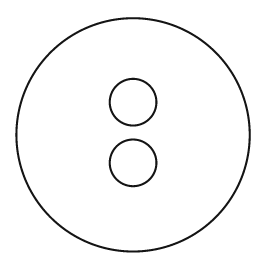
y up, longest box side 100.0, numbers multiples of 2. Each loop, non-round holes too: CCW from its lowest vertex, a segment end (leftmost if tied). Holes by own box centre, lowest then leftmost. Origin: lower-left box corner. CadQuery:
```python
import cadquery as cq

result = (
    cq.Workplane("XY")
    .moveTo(50.0, 50.0)
    .circle(50.0)
    .moveTo(50.0, 38.0)
    .circle(10.0)
    .moveTo(50.0, 64.0)
    .circle(10.0)
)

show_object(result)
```